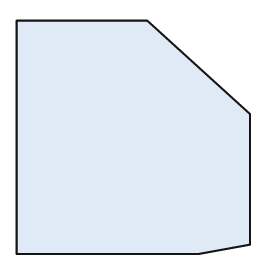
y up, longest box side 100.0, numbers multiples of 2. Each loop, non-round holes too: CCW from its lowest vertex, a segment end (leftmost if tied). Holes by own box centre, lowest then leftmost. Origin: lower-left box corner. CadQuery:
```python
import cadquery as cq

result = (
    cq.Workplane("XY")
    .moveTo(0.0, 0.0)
    .lineTo(78.0, 0.0)
    .lineTo(100.0, 4.0)
    .lineTo(100.0, 60.0)
    .lineTo(56.0, 100.0)
    .lineTo(0.0, 100.0)
    .close()
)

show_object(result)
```